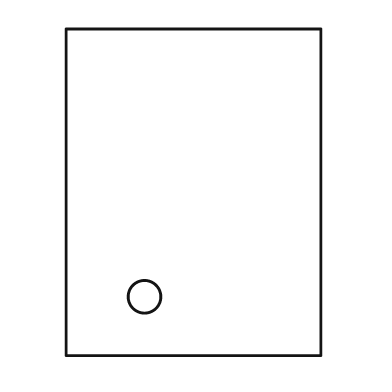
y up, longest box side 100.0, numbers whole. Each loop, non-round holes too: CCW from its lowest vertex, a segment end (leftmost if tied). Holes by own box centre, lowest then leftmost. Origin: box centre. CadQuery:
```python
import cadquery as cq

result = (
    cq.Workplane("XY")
    .moveTo(-39.0, -50.0)
    .lineTo(39.0, -50.0)
    .lineTo(39.0, 50.0)
    .lineTo(-39.0, 50.0)
    .close()
    .moveTo(-15.0, -32.0)
    .circle(5.0)
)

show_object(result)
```